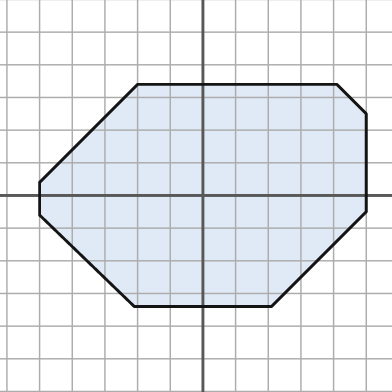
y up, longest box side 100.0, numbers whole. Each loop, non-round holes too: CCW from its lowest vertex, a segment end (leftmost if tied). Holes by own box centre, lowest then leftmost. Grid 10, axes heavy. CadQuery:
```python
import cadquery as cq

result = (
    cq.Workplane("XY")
    .moveTo(-21.0, -34.0)
    .lineTo(21.0, -34.0)
    .lineTo(50.0, -5.0)
    .lineTo(50.0, 25.0)
    .lineTo(41.0, 34.0)
    .lineTo(-20.0, 34.0)
    .lineTo(-50.0, 4.0)
    .lineTo(-50.0, -6.0)
    .close()
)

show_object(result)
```